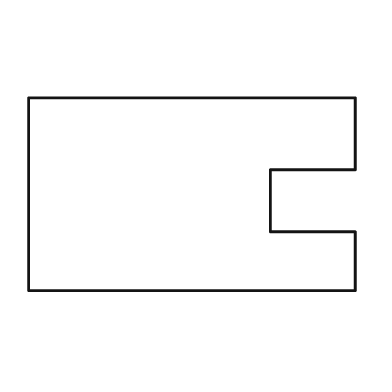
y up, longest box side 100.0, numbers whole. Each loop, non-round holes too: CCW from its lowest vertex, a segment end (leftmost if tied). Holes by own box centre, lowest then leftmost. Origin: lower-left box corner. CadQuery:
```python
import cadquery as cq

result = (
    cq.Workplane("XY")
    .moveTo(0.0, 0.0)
    .lineTo(100.0, 0.0)
    .lineTo(100.0, 18.0)
    .lineTo(74.0, 18.0)
    .lineTo(74.0, 37.0)
    .lineTo(100.0, 37.0)
    .lineTo(100.0, 59.0)
    .lineTo(0.0, 59.0)
    .close()
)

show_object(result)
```